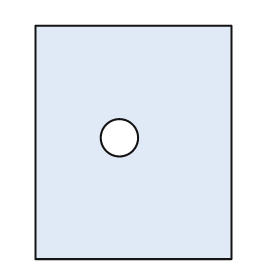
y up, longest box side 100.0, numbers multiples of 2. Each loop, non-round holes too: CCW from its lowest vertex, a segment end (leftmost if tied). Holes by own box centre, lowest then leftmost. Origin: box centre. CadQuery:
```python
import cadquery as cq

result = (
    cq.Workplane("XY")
    .moveTo(-42.0, -50.0)
    .lineTo(42.0, -50.0)
    .lineTo(42.0, 50.0)
    .lineTo(-42.0, 50.0)
    .close()
    .moveTo(-6.0, 2.0)
    .circle(8.0)
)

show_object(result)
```